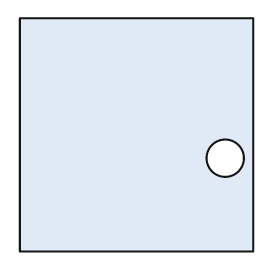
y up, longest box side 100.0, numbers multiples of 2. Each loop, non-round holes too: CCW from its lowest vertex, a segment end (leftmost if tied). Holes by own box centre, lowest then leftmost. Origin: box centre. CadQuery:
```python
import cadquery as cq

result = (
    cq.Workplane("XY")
    .moveTo(-50.0, -50.0)
    .lineTo(50.0, -50.0)
    .lineTo(50.0, 50.0)
    .lineTo(-50.0, 50.0)
    .close()
    .moveTo(38.0, -10.0)
    .circle(8.0)
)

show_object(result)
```